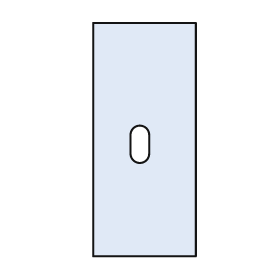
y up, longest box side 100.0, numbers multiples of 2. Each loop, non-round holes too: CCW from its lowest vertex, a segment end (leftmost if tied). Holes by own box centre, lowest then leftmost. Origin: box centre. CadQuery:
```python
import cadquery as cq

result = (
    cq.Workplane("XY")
    .moveTo(-22.0, -50.0)
    .lineTo(22.0, -50.0)
    .lineTo(22.0, 50.0)
    .lineTo(-22.0, 50.0)
    .close()
    .moveTo(-6.0, -6.0)
    .threePointArc((-2.0, -10.0), (2.0, -6.0))
    .lineTo(2.0, 2.0)
    .threePointArc((-2.0, 6.0), (-6.0, 2.0))
    .close()
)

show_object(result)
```